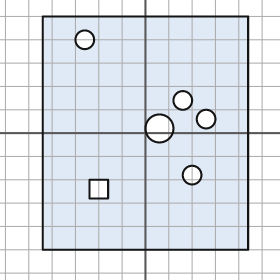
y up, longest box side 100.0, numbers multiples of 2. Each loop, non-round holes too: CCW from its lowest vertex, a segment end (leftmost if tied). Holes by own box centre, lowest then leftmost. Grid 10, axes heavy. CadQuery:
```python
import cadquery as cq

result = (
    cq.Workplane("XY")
    .moveTo(-44.0, -50.0)
    .lineTo(44.0, -50.0)
    .lineTo(44.0, 50.0)
    .lineTo(-44.0, 50.0)
    .close()
    .moveTo(-24.0, -28.0)
    .lineTo(-16.0, -28.0)
    .lineTo(-16.0, -20.0)
    .lineTo(-24.0, -20.0)
    .close()
    .moveTo(20.0, -18.0)
    .circle(4.0)
    .moveTo(6.0, 2.0)
    .circle(6.0)
    .moveTo(26.0, 6.0)
    .circle(4.0)
    .moveTo(16.0, 14.0)
    .circle(4.0)
    .moveTo(-26.0, 40.0)
    .circle(4.0)
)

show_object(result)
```